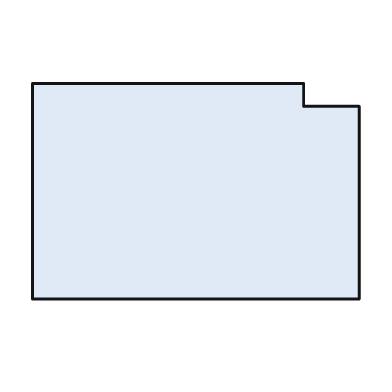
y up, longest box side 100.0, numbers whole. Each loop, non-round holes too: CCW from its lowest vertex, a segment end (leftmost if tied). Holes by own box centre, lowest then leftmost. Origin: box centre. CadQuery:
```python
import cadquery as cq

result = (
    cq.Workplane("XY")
    .moveTo(-50.0, -33.0)
    .lineTo(50.0, -33.0)
    .lineTo(50.0, 26.0)
    .lineTo(33.0, 26.0)
    .lineTo(33.0, 33.0)
    .lineTo(-50.0, 33.0)
    .close()
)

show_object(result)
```